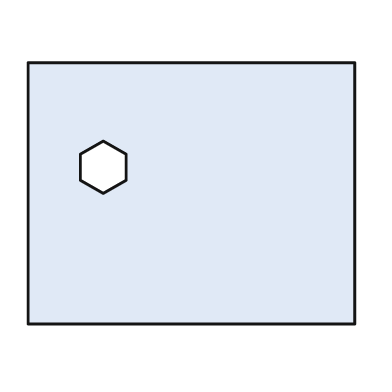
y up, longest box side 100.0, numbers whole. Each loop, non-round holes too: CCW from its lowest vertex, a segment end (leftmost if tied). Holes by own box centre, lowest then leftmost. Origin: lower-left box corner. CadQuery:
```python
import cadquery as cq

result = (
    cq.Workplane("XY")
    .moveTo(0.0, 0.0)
    .lineTo(100.0, 0.0)
    .lineTo(100.0, 80.0)
    .lineTo(0.0, 80.0)
    .close()
    .moveTo(23.0, 40.0)
    .lineTo(30.0, 44.0)
    .lineTo(30.0, 52.0)
    .lineTo(23.0, 56.0)
    .lineTo(16.0, 52.0)
    .lineTo(16.0, 44.0)
    .close()
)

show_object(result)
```